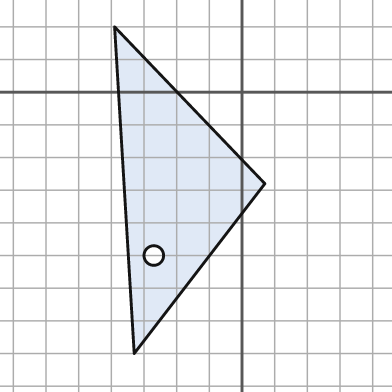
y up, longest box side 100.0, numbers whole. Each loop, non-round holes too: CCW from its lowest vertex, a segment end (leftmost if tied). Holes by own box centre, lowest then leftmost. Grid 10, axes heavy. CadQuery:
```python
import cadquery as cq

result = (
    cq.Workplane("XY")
    .moveTo(-33.0, -80.0)
    .lineTo(7.0, -28.0)
    .lineTo(-39.0, 20.0)
    .close()
    .moveTo(-27.0, -50.0)
    .circle(3.0)
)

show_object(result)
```